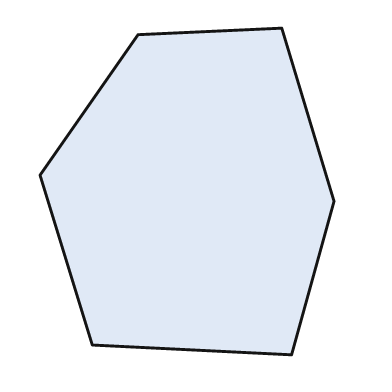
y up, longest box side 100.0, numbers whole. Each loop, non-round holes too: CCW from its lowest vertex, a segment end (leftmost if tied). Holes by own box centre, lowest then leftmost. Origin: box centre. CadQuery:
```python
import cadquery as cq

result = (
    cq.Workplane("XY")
    .moveTo(32.0, -50.0)
    .lineTo(45.0, -3.0)
    .lineTo(29.0, 50.0)
    .lineTo(-15.0, 48.0)
    .lineTo(-45.0, 5.0)
    .lineTo(-29.0, -47.0)
    .close()
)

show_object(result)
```